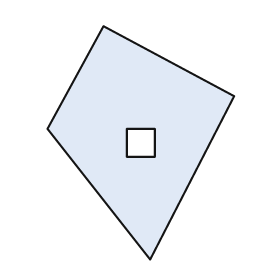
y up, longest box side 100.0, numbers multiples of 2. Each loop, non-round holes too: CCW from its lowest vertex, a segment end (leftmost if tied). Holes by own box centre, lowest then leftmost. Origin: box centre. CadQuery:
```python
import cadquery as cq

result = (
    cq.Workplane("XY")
    .moveTo(4.0, -50.0)
    .lineTo(40.0, 20.0)
    .lineTo(-16.0, 50.0)
    .lineTo(-40.0, 6.0)
    .close()
    .moveTo(-6.0, -6.0)
    .lineTo(6.0, -6.0)
    .lineTo(6.0, 6.0)
    .lineTo(-6.0, 6.0)
    .close()
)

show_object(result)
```